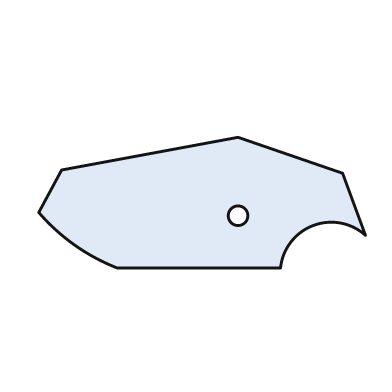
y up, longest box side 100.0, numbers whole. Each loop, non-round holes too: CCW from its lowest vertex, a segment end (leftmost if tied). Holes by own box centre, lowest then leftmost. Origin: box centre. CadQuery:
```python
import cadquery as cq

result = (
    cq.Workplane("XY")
    .moveTo(-26.0, -20.0)
    .lineTo(24.0, -20.0)
    .threePointArc((34.0, -7.0), (50.0, -10.0))
    .lineTo(43.0, 9.0)
    .lineTo(11.0, 20.0)
    .lineTo(-43.0, 10.0)
    .lineTo(-50.0, -3.0)
    .threePointArc((-39.0, -13.0), (-26.0, -20.0))
    .close()
    .moveTo(11.0, -4.0)
    .circle(3.0)
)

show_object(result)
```